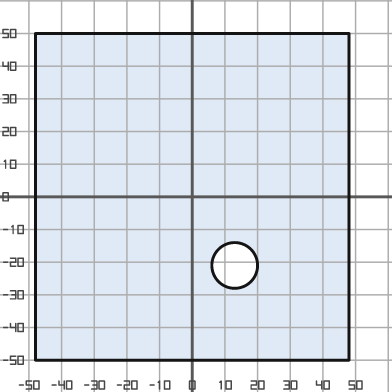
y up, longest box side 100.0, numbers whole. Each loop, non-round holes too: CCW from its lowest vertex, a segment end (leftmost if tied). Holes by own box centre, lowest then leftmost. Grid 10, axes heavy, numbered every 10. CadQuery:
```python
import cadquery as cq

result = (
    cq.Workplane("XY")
    .moveTo(-48.0, -50.0)
    .lineTo(48.0, -50.0)
    .lineTo(48.0, 50.0)
    .lineTo(-48.0, 50.0)
    .close()
    .moveTo(13.0, -21.0)
    .circle(7.0)
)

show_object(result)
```